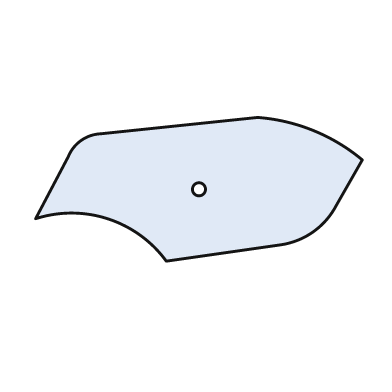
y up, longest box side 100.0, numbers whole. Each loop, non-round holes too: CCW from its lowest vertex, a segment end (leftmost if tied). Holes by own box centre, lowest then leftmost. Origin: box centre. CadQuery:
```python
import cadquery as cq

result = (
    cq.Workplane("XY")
    .moveTo(-10.0, -22.0)
    .lineTo(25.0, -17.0)
    .threePointArc((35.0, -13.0), (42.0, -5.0))
    .lineTo(50.0, 9.0)
    .threePointArc((35.0, 18.0), (18.0, 22.0))
    .lineTo(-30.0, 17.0)
    .threePointArc((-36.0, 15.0), (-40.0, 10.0))
    .lineTo(-50.0, -9.0)
    .threePointArc((-28.0, -9.0), (-10.0, -22.0))
    .close()
    .moveTo(0.0, 0.0)
    .circle(2.0)
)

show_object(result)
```